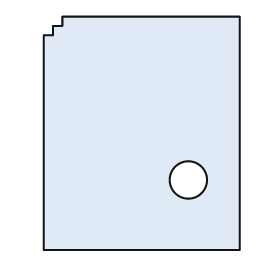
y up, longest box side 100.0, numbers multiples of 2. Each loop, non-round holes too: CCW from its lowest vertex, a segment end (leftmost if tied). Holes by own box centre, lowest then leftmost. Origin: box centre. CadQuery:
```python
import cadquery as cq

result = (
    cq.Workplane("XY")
    .moveTo(-42.0, -50.0)
    .lineTo(42.0, -50.0)
    .lineTo(42.0, 50.0)
    .lineTo(-34.0, 50.0)
    .lineTo(-34.0, 46.0)
    .lineTo(-38.0, 46.0)
    .lineTo(-38.0, 42.0)
    .lineTo(-42.0, 42.0)
    .close()
    .moveTo(20.0, -20.0)
    .circle(8.0)
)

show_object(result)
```